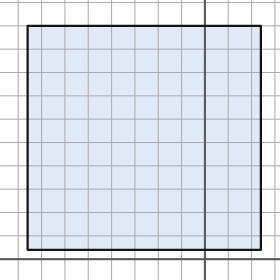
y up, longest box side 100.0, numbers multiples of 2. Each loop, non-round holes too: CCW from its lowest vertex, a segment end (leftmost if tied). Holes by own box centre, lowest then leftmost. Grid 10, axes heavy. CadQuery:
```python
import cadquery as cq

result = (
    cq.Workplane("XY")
    .moveTo(-76.0, 4.0)
    .lineTo(24.0, 4.0)
    .lineTo(24.0, 100.0)
    .lineTo(-76.0, 100.0)
    .close()
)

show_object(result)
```